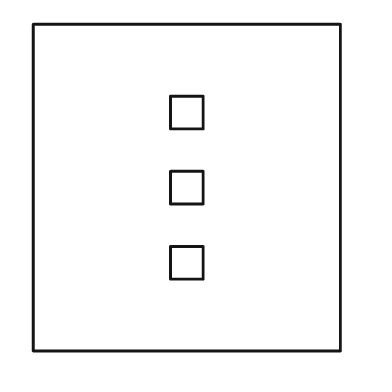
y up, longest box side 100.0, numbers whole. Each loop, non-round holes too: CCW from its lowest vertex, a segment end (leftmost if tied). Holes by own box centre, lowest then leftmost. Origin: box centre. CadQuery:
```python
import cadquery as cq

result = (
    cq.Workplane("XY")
    .moveTo(-47.0, -50.0)
    .lineTo(47.0, -50.0)
    .lineTo(47.0, 50.0)
    .lineTo(-47.0, 50.0)
    .close()
    .moveTo(-5.0, -28.0)
    .lineTo(5.0, -28.0)
    .lineTo(5.0, -18.0)
    .lineTo(-5.0, -18.0)
    .close()
    .moveTo(-5.0, -5.0)
    .lineTo(5.0, -5.0)
    .lineTo(5.0, 5.0)
    .lineTo(-5.0, 5.0)
    .close()
    .moveTo(-5.0, 18.0)
    .lineTo(5.0, 18.0)
    .lineTo(5.0, 28.0)
    .lineTo(-5.0, 28.0)
    .close()
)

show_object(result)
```